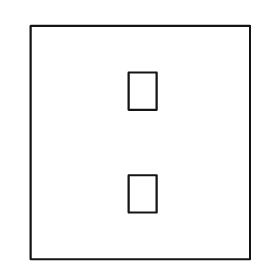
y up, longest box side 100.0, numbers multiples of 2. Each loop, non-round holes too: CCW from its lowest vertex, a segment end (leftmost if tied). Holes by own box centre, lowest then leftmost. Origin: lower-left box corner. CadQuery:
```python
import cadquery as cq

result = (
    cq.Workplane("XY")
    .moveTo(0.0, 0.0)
    .lineTo(94.0, 0.0)
    .lineTo(94.0, 100.0)
    .lineTo(0.0, 100.0)
    .close()
    .moveTo(42.0, 20.0)
    .lineTo(54.0, 20.0)
    .lineTo(54.0, 36.0)
    .lineTo(42.0, 36.0)
    .close()
    .moveTo(42.0, 64.0)
    .lineTo(54.0, 64.0)
    .lineTo(54.0, 80.0)
    .lineTo(42.0, 80.0)
    .close()
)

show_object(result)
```